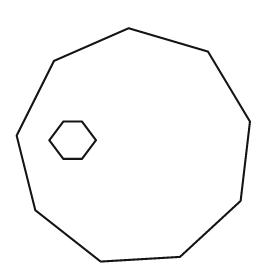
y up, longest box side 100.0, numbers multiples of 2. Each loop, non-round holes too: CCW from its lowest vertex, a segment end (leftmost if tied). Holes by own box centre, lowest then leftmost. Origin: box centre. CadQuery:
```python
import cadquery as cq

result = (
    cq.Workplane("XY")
    .moveTo(-14.0, -50.0)
    .lineTo(20.0, -48.0)
    .lineTo(46.0, -24.0)
    .lineTo(50.0, 10.0)
    .lineTo(32.0, 40.0)
    .lineTo(-2.0, 50.0)
    .lineTo(-34.0, 36.0)
    .lineTo(-50.0, 4.0)
    .lineTo(-42.0, -28.0)
    .close()
    .moveTo(-30.0, -6.0)
    .lineTo(-22.0, -6.0)
    .lineTo(-16.0, 2.0)
    .lineTo(-22.0, 10.0)
    .lineTo(-30.0, 10.0)
    .lineTo(-36.0, 2.0)
    .close()
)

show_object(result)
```